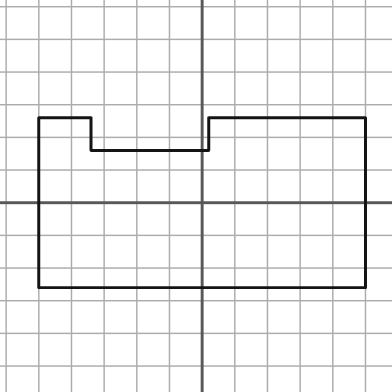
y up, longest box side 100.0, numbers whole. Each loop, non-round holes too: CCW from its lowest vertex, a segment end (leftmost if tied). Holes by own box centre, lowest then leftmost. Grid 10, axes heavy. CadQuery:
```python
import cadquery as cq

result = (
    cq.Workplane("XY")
    .moveTo(-50.0, -26.0)
    .lineTo(50.0, -26.0)
    .lineTo(50.0, 26.0)
    .lineTo(2.0, 26.0)
    .lineTo(2.0, 16.0)
    .lineTo(-34.0, 16.0)
    .lineTo(-34.0, 26.0)
    .lineTo(-50.0, 26.0)
    .close()
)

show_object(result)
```